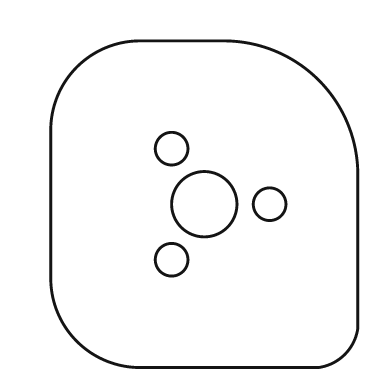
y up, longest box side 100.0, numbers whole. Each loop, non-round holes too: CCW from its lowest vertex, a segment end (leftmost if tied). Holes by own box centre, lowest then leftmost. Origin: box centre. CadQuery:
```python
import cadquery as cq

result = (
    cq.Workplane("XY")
    .moveTo(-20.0, -50.0)
    .lineTo(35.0, -50.0)
    .threePointArc((43.0, -46.0), (47.0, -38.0))
    .lineTo(47.0, 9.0)
    .threePointArc((35.0, 38.0), (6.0, 50.0))
    .lineTo(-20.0, 50.0)
    .threePointArc((-39.0, 42.0), (-47.0, 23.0))
    .lineTo(-47.0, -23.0)
    .threePointArc((-39.0, -42.0), (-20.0, -50.0))
    .close()
    .moveTo(-10.0, -17.0)
    .circle(5.0)
    .moveTo(0.0, 0.0)
    .circle(10.0)
    .moveTo(20.0, 0.0)
    .circle(5.0)
    .moveTo(-10.0, 17.0)
    .circle(5.0)
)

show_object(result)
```